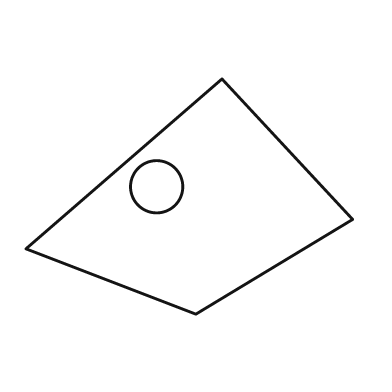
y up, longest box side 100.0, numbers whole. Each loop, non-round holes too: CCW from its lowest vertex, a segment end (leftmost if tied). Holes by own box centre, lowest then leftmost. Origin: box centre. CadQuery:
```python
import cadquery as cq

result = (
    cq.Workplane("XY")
    .moveTo(2.0, -36.0)
    .lineTo(50.0, -7.0)
    .lineTo(10.0, 36.0)
    .lineTo(-50.0, -16.0)
    .close()
    .moveTo(-10.0, 3.0)
    .circle(8.0)
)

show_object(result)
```